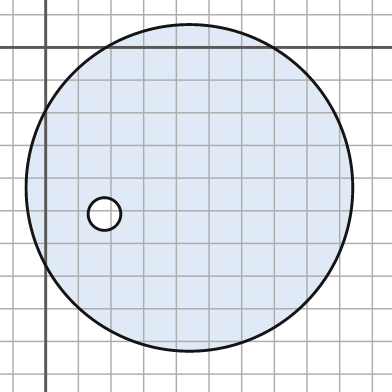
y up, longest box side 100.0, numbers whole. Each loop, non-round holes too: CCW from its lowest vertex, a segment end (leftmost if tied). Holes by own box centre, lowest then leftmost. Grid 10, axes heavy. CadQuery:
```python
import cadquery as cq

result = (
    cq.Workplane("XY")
    .moveTo(44.0, -43.0)
    .circle(50.0)
    .moveTo(18.0, -51.0)
    .circle(5.0)
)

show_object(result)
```